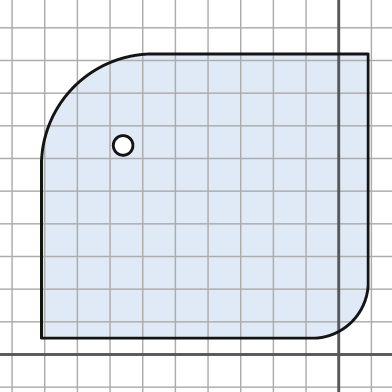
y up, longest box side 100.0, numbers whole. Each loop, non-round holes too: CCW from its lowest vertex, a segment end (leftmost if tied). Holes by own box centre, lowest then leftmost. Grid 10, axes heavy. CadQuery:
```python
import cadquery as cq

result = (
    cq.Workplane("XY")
    .moveTo(-91.0, 5.0)
    .lineTo(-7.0, 5.0)
    .threePointArc((4.0, 10.0), (9.0, 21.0))
    .lineTo(9.0, 92.0)
    .lineTo(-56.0, 92.0)
    .threePointArc((-81.0, 82.0), (-91.0, 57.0))
    .close()
    .moveTo(-66.0, 64.0)
    .circle(3.0)
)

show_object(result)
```